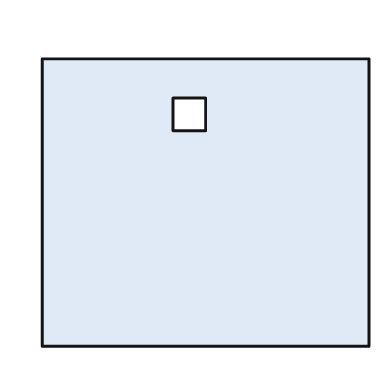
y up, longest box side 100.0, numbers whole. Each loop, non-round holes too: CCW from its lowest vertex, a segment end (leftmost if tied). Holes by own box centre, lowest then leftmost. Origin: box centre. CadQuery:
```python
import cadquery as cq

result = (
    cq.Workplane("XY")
    .moveTo(-50.0, -44.0)
    .lineTo(50.0, -44.0)
    .lineTo(50.0, 44.0)
    .lineTo(-50.0, 44.0)
    .close()
    .moveTo(-10.0, 22.0)
    .lineTo(0.0, 22.0)
    .lineTo(0.0, 32.0)
    .lineTo(-10.0, 32.0)
    .close()
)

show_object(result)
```